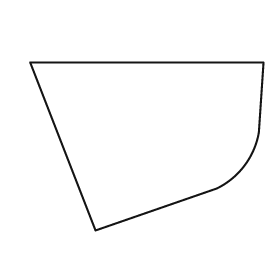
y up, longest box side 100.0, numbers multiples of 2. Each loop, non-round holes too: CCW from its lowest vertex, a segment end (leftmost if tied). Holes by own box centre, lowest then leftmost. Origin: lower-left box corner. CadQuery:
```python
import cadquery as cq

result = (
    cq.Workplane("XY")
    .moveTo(28.0, 0.0)
    .lineTo(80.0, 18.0)
    .threePointArc((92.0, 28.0), (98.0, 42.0))
    .lineTo(100.0, 72.0)
    .lineTo(0.0, 72.0)
    .close()
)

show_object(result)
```